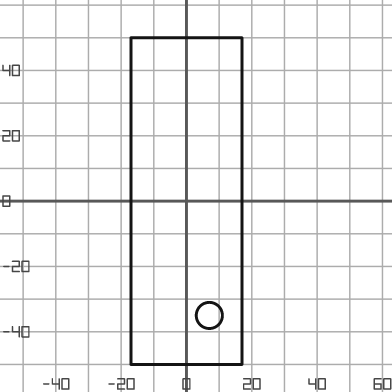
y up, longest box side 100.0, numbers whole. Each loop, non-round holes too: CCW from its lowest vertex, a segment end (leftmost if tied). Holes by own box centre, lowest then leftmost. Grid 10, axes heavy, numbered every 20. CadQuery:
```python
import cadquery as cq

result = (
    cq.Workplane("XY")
    .moveTo(-17.0, -50.0)
    .lineTo(17.0, -50.0)
    .lineTo(17.0, 50.0)
    .lineTo(-17.0, 50.0)
    .close()
    .moveTo(7.0, -35.0)
    .circle(4.0)
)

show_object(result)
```